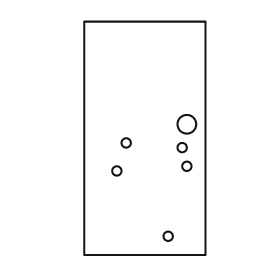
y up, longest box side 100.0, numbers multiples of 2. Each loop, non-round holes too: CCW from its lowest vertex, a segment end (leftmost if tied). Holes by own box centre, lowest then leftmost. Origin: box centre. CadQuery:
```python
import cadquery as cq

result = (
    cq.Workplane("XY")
    .moveTo(-26.0, -50.0)
    .lineTo(26.0, -50.0)
    .lineTo(26.0, 50.0)
    .lineTo(-26.0, 50.0)
    .close()
    .moveTo(10.0, -42.0)
    .circle(2.0)
    .moveTo(-12.0, -14.0)
    .circle(2.0)
    .moveTo(18.0, -12.0)
    .circle(2.0)
    .moveTo(16.0, -4.0)
    .circle(2.0)
    .moveTo(-8.0, -2.0)
    .circle(2.0)
    .moveTo(18.0, 6.0)
    .circle(4.0)
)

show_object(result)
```